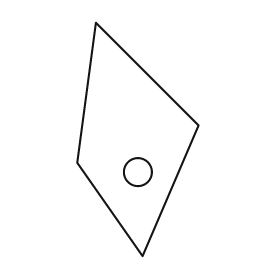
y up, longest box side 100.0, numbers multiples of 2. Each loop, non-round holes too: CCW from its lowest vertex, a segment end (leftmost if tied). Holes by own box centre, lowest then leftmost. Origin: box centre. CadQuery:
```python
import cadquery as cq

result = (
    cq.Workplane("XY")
    .moveTo(2.0, -50.0)
    .lineTo(26.0, 6.0)
    .lineTo(-18.0, 50.0)
    .lineTo(-26.0, -10.0)
    .close()
    .moveTo(0.0, -14.0)
    .circle(6.0)
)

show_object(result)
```